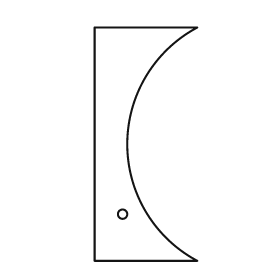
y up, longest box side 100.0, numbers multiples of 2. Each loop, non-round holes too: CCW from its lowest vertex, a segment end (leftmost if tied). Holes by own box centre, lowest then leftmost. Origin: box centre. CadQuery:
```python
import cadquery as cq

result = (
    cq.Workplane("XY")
    .moveTo(-22.0, -50.0)
    .lineTo(22.0, -50.0)
    .threePointArc((-8.0, 0.0), (22.0, 50.0))
    .lineTo(-22.0, 50.0)
    .close()
    .moveTo(-10.0, -30.0)
    .circle(2.0)
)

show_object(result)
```